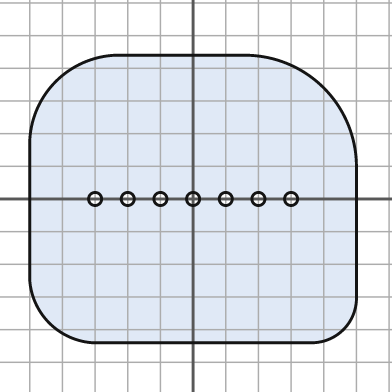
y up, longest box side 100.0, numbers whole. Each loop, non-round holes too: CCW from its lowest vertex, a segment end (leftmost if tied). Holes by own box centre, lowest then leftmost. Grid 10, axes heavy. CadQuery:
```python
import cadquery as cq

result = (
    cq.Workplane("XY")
    .moveTo(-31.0, -44.0)
    .lineTo(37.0, -44.0)
    .threePointArc((46.0, -40.0), (50.0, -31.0))
    .lineTo(50.0, 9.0)
    .threePointArc((40.0, 34.0), (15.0, 44.0))
    .lineTo(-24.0, 44.0)
    .threePointArc((-42.0, 36.0), (-50.0, 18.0))
    .lineTo(-50.0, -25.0)
    .threePointArc((-44.0, -38.0), (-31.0, -44.0))
    .close()
    .moveTo(-30.0, 0.0)
    .circle(2.0)
    .moveTo(-20.0, 0.0)
    .circle(2.0)
    .moveTo(-10.0, 0.0)
    .circle(2.0)
    .moveTo(0.0, 0.0)
    .circle(2.0)
    .moveTo(10.0, 0.0)
    .circle(2.0)
    .moveTo(20.0, 0.0)
    .circle(2.0)
    .moveTo(30.0, 0.0)
    .circle(2.0)
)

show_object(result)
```